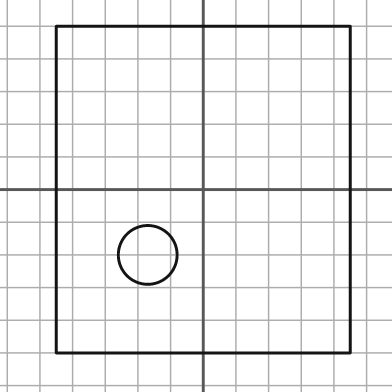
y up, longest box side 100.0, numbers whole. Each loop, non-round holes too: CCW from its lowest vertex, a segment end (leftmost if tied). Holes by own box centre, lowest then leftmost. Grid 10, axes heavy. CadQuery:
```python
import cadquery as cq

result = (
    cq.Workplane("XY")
    .moveTo(-45.0, -50.0)
    .lineTo(45.0, -50.0)
    .lineTo(45.0, 50.0)
    .lineTo(-45.0, 50.0)
    .close()
    .moveTo(-17.0, -20.0)
    .circle(9.0)
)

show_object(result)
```